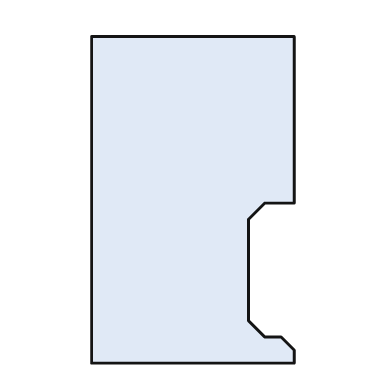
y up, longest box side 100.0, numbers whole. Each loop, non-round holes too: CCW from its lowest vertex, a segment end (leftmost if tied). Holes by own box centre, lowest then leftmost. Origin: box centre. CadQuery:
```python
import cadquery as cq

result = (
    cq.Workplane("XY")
    .moveTo(-31.0, -50.0)
    .lineTo(31.0, -50.0)
    .lineTo(31.0, -46.0)
    .lineTo(27.0, -42.0)
    .lineTo(22.0, -42.0)
    .lineTo(17.0, -37.0)
    .lineTo(17.0, -6.0)
    .lineTo(22.0, -1.0)
    .lineTo(31.0, -1.0)
    .lineTo(31.0, 50.0)
    .lineTo(-31.0, 50.0)
    .close()
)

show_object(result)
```